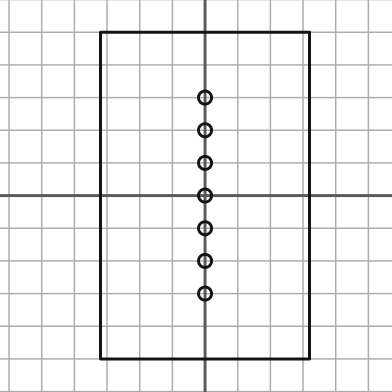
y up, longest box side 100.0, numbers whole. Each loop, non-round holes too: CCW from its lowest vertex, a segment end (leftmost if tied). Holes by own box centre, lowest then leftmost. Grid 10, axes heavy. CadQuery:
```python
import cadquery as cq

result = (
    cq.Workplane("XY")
    .moveTo(-32.0, -50.0)
    .lineTo(32.0, -50.0)
    .lineTo(32.0, 50.0)
    .lineTo(-32.0, 50.0)
    .close()
    .moveTo(0.0, -30.0)
    .circle(2.0)
    .moveTo(0.0, -20.0)
    .circle(2.0)
    .moveTo(0.0, -10.0)
    .circle(2.0)
    .moveTo(0.0, 0.0)
    .circle(2.0)
    .moveTo(0.0, 10.0)
    .circle(2.0)
    .moveTo(0.0, 20.0)
    .circle(2.0)
    .moveTo(0.0, 30.0)
    .circle(2.0)
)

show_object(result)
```